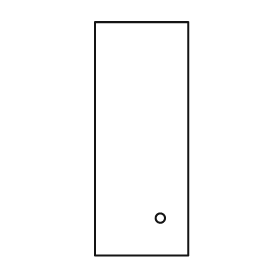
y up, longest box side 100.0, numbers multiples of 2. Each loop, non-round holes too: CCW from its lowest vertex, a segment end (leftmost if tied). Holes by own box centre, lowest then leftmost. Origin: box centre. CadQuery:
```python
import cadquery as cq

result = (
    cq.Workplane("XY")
    .moveTo(-20.0, -50.0)
    .lineTo(20.0, -50.0)
    .lineTo(20.0, 50.0)
    .lineTo(-20.0, 50.0)
    .close()
    .moveTo(8.0, -34.0)
    .circle(2.0)
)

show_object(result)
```